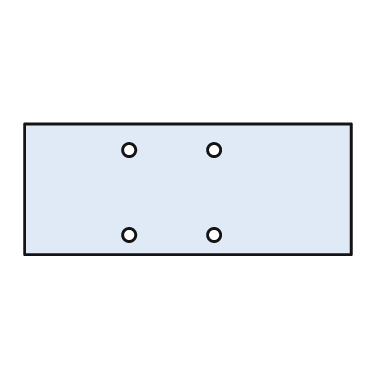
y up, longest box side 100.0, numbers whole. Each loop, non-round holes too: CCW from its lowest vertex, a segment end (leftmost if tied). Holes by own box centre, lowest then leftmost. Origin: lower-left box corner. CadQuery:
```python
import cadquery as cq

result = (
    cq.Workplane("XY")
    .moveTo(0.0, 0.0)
    .lineTo(100.0, 0.0)
    .lineTo(100.0, 40.0)
    .lineTo(0.0, 40.0)
    .close()
    .moveTo(32.0, 6.0)
    .circle(2.0)
    .moveTo(58.0, 6.0)
    .circle(2.0)
    .moveTo(32.0, 32.0)
    .circle(2.0)
    .moveTo(58.0, 32.0)
    .circle(2.0)
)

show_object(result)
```